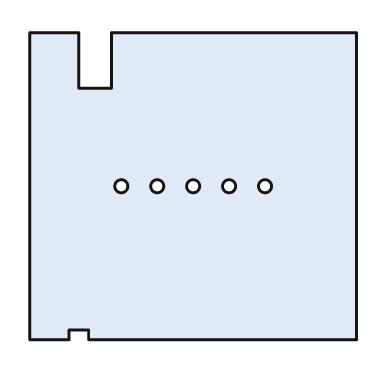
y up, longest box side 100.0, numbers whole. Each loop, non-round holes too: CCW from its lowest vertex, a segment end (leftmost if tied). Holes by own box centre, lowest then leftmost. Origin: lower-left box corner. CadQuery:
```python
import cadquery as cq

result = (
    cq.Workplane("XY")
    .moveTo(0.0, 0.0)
    .lineTo(12.0, 0.0)
    .lineTo(12.0, 3.0)
    .lineTo(18.0, 3.0)
    .lineTo(18.0, 0.0)
    .lineTo(100.0, 0.0)
    .lineTo(100.0, 94.0)
    .lineTo(25.0, 94.0)
    .lineTo(25.0, 77.0)
    .lineTo(15.0, 77.0)
    .lineTo(15.0, 94.0)
    .lineTo(0.0, 94.0)
    .close()
    .moveTo(28.0, 47.0)
    .circle(2.0)
    .moveTo(39.0, 47.0)
    .circle(2.0)
    .moveTo(50.0, 47.0)
    .circle(2.0)
    .moveTo(61.0, 47.0)
    .circle(2.0)
    .moveTo(72.0, 47.0)
    .circle(2.0)
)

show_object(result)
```